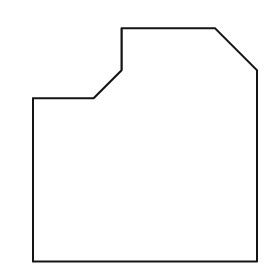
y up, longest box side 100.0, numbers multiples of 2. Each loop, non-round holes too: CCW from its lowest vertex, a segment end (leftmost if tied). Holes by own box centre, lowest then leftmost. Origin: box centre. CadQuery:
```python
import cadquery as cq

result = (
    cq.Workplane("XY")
    .moveTo(-48.0, -50.0)
    .lineTo(48.0, -50.0)
    .lineTo(48.0, 32.0)
    .lineTo(30.0, 50.0)
    .lineTo(-10.0, 50.0)
    .lineTo(-10.0, 32.0)
    .lineTo(-22.0, 20.0)
    .lineTo(-48.0, 20.0)
    .close()
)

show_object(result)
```